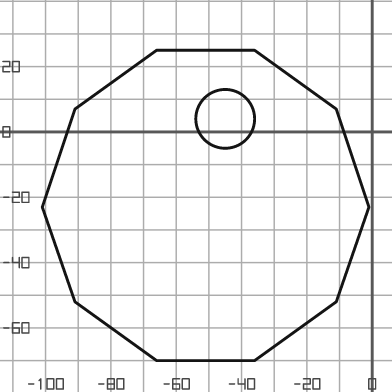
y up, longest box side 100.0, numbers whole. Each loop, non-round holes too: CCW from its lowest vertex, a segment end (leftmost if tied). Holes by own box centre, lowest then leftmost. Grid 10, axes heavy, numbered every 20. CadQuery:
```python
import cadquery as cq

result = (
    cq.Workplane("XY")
    .moveTo(-66.0, -70.0)
    .lineTo(-36.0, -70.0)
    .lineTo(-11.0, -52.0)
    .lineTo(-1.0, -23.0)
    .lineTo(-11.0, 7.0)
    .lineTo(-36.0, 25.0)
    .lineTo(-66.0, 25.0)
    .lineTo(-91.0, 7.0)
    .lineTo(-101.0, -23.0)
    .lineTo(-91.0, -52.0)
    .close()
    .moveTo(-45.0, 4.0)
    .circle(9.0)
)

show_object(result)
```